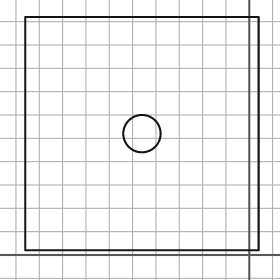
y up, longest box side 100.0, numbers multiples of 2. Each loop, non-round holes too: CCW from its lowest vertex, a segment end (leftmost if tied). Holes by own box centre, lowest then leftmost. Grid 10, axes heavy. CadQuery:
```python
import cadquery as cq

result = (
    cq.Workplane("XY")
    .moveTo(-96.0, 2.0)
    .lineTo(4.0, 2.0)
    .lineTo(4.0, 102.0)
    .lineTo(-96.0, 102.0)
    .close()
    .moveTo(-46.0, 52.0)
    .circle(8.0)
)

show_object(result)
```